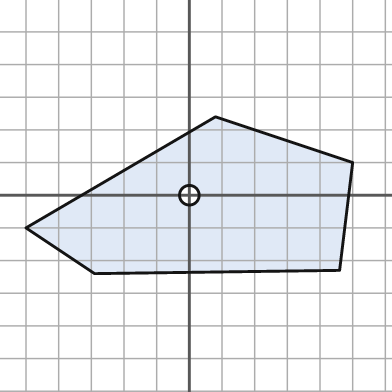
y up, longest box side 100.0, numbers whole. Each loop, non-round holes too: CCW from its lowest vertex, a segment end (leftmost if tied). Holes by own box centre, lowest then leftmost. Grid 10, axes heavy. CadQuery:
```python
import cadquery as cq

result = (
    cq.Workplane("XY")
    .moveTo(-29.0, -24.0)
    .lineTo(46.0, -23.0)
    .lineTo(50.0, 10.0)
    .lineTo(8.0, 24.0)
    .lineTo(-50.0, -10.0)
    .close()
    .moveTo(0.0, 0.0)
    .circle(3.0)
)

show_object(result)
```